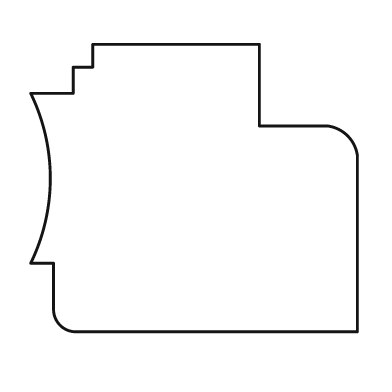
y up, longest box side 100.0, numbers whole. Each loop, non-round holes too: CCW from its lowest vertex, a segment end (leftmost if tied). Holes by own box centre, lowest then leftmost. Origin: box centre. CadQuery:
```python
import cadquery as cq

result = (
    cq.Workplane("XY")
    .moveTo(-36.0, -44.0)
    .lineTo(50.0, -44.0)
    .lineTo(50.0, 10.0)
    .threePointArc((47.0, 16.0), (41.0, 19.0))
    .lineTo(20.0, 19.0)
    .lineTo(20.0, 44.0)
    .lineTo(-31.0, 44.0)
    .lineTo(-31.0, 37.0)
    .lineTo(-37.0, 37.0)
    .lineTo(-37.0, 29.0)
    .lineTo(-50.0, 29.0)
    .threePointArc((-44.0, 3.0), (-50.0, -23.0))
    .lineTo(-43.0, -23.0)
    .lineTo(-43.0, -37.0)
    .threePointArc((-41.0, -42.0), (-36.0, -44.0))
    .close()
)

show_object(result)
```